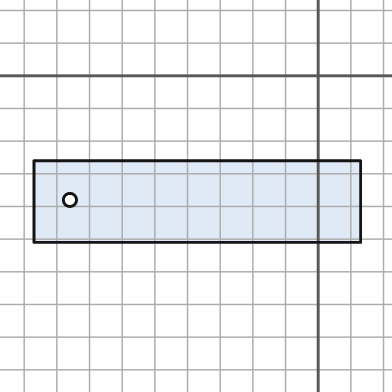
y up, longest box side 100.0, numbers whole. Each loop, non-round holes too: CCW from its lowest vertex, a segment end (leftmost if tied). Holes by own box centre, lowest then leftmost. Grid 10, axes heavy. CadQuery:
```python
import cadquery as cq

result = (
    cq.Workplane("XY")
    .moveTo(-87.0, -51.0)
    .lineTo(13.0, -51.0)
    .lineTo(13.0, -26.0)
    .lineTo(-87.0, -26.0)
    .close()
    .moveTo(-76.0, -38.0)
    .circle(2.0)
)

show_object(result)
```